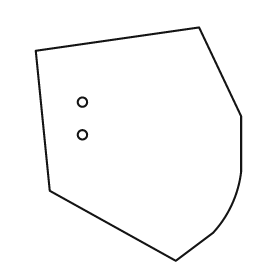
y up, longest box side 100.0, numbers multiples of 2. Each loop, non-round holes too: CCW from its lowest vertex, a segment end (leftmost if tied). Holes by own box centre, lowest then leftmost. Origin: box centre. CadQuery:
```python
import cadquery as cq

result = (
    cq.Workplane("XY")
    .moveTo(16.0, -50.0)
    .lineTo(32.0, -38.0)
    .threePointArc((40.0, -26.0), (44.0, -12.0))
    .lineTo(44.0, 12.0)
    .lineTo(26.0, 50.0)
    .lineTo(-44.0, 40.0)
    .lineTo(-38.0, -20.0)
    .close()
    .moveTo(-24.0, 4.0)
    .circle(2.0)
    .moveTo(-24.0, 18.0)
    .circle(2.0)
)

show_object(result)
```